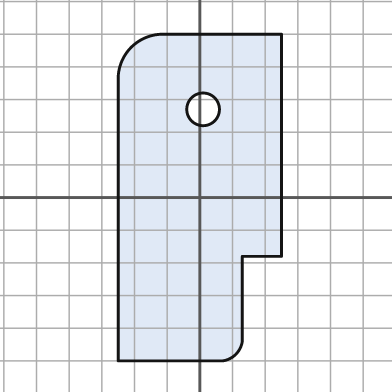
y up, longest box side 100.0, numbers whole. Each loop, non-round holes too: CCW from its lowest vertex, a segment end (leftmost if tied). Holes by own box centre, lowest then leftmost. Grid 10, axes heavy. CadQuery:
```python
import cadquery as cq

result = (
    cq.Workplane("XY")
    .moveTo(-25.0, -50.0)
    .lineTo(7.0, -50.0)
    .threePointArc((11.0, -48.0), (13.0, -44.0))
    .lineTo(13.0, -18.0)
    .lineTo(25.0, -18.0)
    .lineTo(25.0, 50.0)
    .lineTo(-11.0, 50.0)
    .threePointArc((-21.0, 46.0), (-25.0, 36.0))
    .close()
    .moveTo(1.0, 27.0)
    .circle(5.0)
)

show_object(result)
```